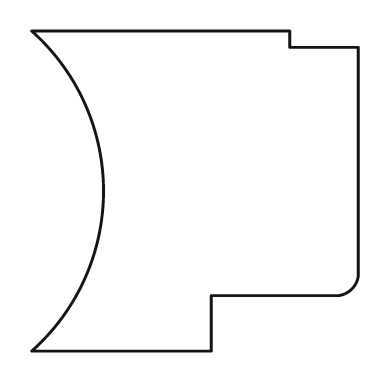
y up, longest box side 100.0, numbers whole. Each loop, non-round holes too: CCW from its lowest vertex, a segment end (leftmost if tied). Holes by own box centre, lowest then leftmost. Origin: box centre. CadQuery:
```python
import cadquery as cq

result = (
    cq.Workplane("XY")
    .moveTo(-50.0, -49.0)
    .lineTo(5.0, -49.0)
    .lineTo(5.0, -32.0)
    .lineTo(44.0, -32.0)
    .threePointArc((48.0, -30.0), (50.0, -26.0))
    .lineTo(50.0, 44.0)
    .lineTo(29.0, 44.0)
    .lineTo(29.0, 49.0)
    .lineTo(-50.0, 49.0)
    .threePointArc((-28.0, 0.0), (-50.0, -49.0))
    .close()
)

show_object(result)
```